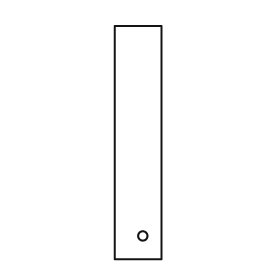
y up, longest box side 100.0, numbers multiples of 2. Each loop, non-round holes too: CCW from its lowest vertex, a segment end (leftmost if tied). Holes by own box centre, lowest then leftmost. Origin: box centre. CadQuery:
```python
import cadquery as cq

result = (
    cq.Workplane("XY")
    .moveTo(-10.0, -50.0)
    .lineTo(10.0, -50.0)
    .lineTo(10.0, 50.0)
    .lineTo(-10.0, 50.0)
    .close()
    .moveTo(2.0, -40.0)
    .circle(2.0)
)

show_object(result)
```